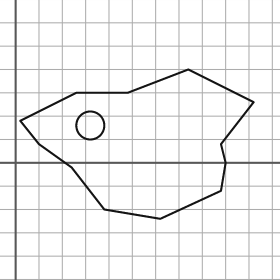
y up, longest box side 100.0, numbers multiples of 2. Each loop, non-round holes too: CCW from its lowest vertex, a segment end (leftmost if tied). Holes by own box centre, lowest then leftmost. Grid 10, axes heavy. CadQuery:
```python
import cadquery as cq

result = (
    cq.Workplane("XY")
    .moveTo(62.0, -24.0)
    .lineTo(88.0, -12.0)
    .lineTo(90.0, 0.0)
    .lineTo(88.0, 8.0)
    .lineTo(102.0, 26.0)
    .lineTo(74.0, 40.0)
    .lineTo(48.0, 30.0)
    .lineTo(26.0, 30.0)
    .lineTo(2.0, 18.0)
    .lineTo(10.0, 8.0)
    .lineTo(24.0, -2.0)
    .lineTo(38.0, -20.0)
    .close()
    .moveTo(32.0, 16.0)
    .circle(6.0)
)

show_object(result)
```